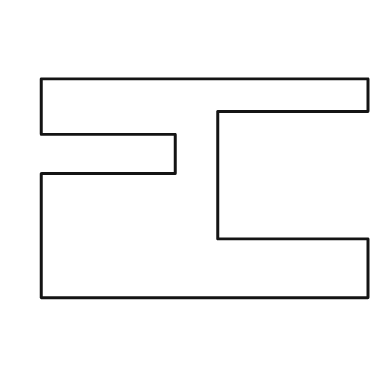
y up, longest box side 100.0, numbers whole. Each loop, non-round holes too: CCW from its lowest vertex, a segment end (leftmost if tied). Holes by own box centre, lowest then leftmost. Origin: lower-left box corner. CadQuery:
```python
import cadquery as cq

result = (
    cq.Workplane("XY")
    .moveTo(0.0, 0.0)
    .lineTo(100.0, 0.0)
    .lineTo(100.0, 18.0)
    .lineTo(54.0, 18.0)
    .lineTo(54.0, 57.0)
    .lineTo(100.0, 57.0)
    .lineTo(100.0, 67.0)
    .lineTo(0.0, 67.0)
    .lineTo(0.0, 50.0)
    .lineTo(41.0, 50.0)
    .lineTo(41.0, 38.0)
    .lineTo(0.0, 38.0)
    .close()
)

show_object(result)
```